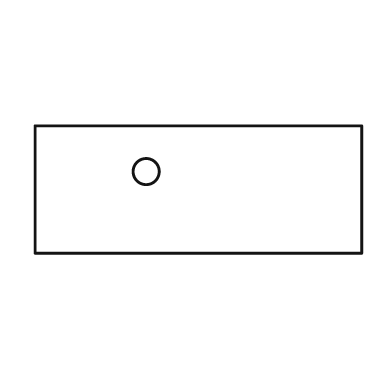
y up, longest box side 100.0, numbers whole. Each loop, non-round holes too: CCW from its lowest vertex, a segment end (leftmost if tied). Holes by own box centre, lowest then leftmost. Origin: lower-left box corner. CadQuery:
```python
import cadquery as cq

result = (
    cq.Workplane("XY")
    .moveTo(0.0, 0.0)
    .lineTo(100.0, 0.0)
    .lineTo(100.0, 39.0)
    .lineTo(0.0, 39.0)
    .close()
    .moveTo(34.0, 25.0)
    .circle(4.0)
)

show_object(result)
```